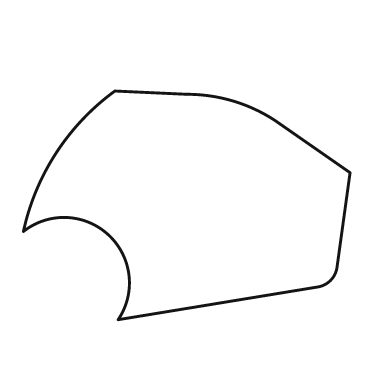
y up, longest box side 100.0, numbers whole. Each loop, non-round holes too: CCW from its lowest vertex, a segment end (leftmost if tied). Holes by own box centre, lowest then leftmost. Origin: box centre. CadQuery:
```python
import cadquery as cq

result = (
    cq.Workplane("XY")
    .moveTo(-21.0, -35.0)
    .lineTo(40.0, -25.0)
    .threePointArc((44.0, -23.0), (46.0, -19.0))
    .lineTo(50.0, 10.0)
    .lineTo(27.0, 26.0)
    .threePointArc((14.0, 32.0), (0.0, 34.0))
    .lineTo(-22.0, 35.0)
    .threePointArc((-40.0, 16.0), (-50.0, -8.0))
    .threePointArc((-24.0, -9.0), (-21.0, -35.0))
    .close()
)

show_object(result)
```